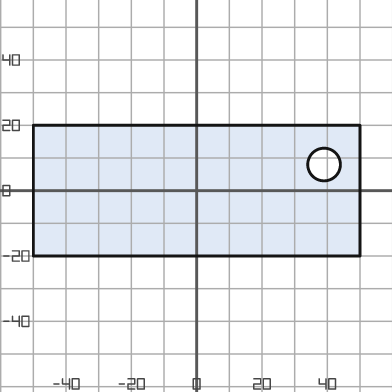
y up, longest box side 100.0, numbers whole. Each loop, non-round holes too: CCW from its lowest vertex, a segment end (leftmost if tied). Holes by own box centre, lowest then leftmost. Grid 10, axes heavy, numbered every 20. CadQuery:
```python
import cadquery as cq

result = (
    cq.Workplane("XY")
    .moveTo(-50.0, -20.0)
    .lineTo(50.0, -20.0)
    .lineTo(50.0, 20.0)
    .lineTo(-50.0, 20.0)
    .close()
    .moveTo(39.0, 8.0)
    .circle(5.0)
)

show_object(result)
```